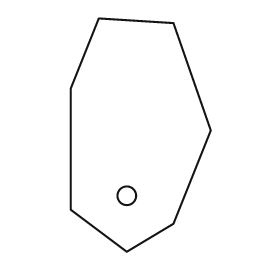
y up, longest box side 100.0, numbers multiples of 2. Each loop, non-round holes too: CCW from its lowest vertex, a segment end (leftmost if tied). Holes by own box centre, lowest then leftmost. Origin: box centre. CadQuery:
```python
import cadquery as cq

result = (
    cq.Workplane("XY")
    .moveTo(-6.0, -50.0)
    .lineTo(14.0, -38.0)
    .lineTo(30.0, 2.0)
    .lineTo(14.0, 48.0)
    .lineTo(-18.0, 50.0)
    .lineTo(-30.0, 20.0)
    .lineTo(-30.0, -32.0)
    .close()
    .moveTo(-6.0, -26.0)
    .circle(4.0)
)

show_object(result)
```